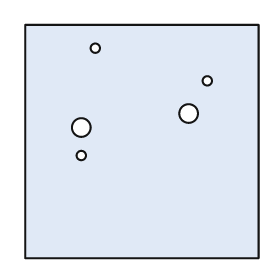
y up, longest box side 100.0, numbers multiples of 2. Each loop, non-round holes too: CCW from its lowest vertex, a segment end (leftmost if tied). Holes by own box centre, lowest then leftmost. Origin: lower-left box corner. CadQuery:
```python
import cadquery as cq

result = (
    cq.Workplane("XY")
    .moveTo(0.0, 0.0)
    .lineTo(100.0, 0.0)
    .lineTo(100.0, 100.0)
    .lineTo(0.0, 100.0)
    .close()
    .moveTo(24.0, 44.0)
    .circle(2.0)
    .moveTo(24.0, 56.0)
    .circle(4.0)
    .moveTo(70.0, 62.0)
    .circle(4.0)
    .moveTo(78.0, 76.0)
    .circle(2.0)
    .moveTo(30.0, 90.0)
    .circle(2.0)
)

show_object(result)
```